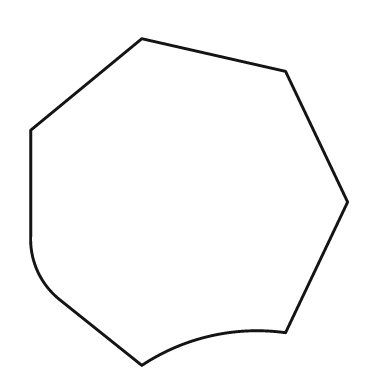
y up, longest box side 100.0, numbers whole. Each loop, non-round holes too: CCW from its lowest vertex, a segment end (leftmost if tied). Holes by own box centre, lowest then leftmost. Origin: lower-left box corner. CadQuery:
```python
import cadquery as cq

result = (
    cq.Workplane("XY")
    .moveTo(34.0, 0.0)
    .threePointArc((55.0, 9.0), (78.0, 10.0))
    .lineTo(97.0, 50.0)
    .lineTo(78.0, 90.0)
    .lineTo(34.0, 100.0)
    .lineTo(0.0, 72.0)
    .lineTo(0.0, 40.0)
    .threePointArc((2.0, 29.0), (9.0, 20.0))
    .close()
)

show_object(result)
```